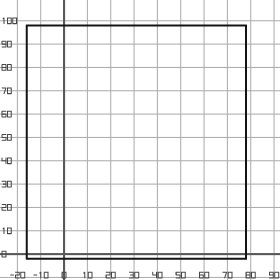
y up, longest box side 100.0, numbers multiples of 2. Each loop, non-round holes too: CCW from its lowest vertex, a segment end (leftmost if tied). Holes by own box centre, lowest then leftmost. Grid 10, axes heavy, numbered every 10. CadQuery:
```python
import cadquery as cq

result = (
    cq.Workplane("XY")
    .moveTo(-16.0, -2.0)
    .lineTo(78.0, -2.0)
    .lineTo(78.0, 98.0)
    .lineTo(-16.0, 98.0)
    .close()
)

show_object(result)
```